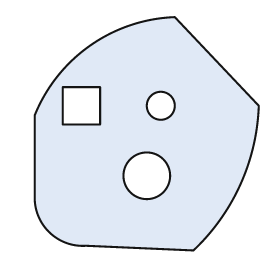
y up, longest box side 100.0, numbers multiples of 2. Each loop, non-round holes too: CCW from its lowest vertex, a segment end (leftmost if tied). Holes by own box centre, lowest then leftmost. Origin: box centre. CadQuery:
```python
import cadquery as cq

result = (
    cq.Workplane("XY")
    .moveTo(20.0, -50.0)
    .threePointArc((40.0, -22.0), (48.0, 12.0))
    .lineTo(12.0, 50.0)
    .threePointArc((-24.0, 38.0), (-48.0, 8.0))
    .lineTo(-48.0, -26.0)
    .threePointArc((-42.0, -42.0), (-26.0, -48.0))
    .close()
    .moveTo(0.0, -18.0)
    .circle(10.0)
    .moveTo(-36.0, 4.0)
    .lineTo(-20.0, 4.0)
    .lineTo(-20.0, 20.0)
    .lineTo(-36.0, 20.0)
    .close()
    .moveTo(6.0, 12.0)
    .circle(6.0)
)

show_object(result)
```